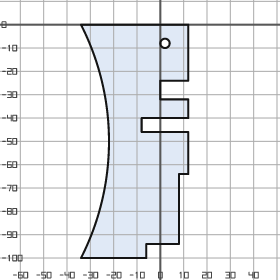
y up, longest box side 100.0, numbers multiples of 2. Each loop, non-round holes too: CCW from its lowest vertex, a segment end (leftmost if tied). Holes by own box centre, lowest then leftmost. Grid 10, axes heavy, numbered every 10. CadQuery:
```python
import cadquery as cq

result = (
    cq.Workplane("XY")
    .moveTo(-34.0, -100.0)
    .lineTo(-6.0, -100.0)
    .lineTo(-6.0, -94.0)
    .lineTo(8.0, -94.0)
    .lineTo(8.0, -64.0)
    .lineTo(12.0, -64.0)
    .lineTo(12.0, -46.0)
    .lineTo(-8.0, -46.0)
    .lineTo(-8.0, -40.0)
    .lineTo(12.0, -40.0)
    .lineTo(12.0, -32.0)
    .lineTo(0.0, -32.0)
    .lineTo(0.0, -24.0)
    .lineTo(12.0, -24.0)
    .lineTo(12.0, 0.0)
    .lineTo(-34.0, 0.0)
    .threePointArc((-22.0, -50.0), (-34.0, -100.0))
    .close()
    .moveTo(2.0, -8.0)
    .circle(2.0)
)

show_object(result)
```